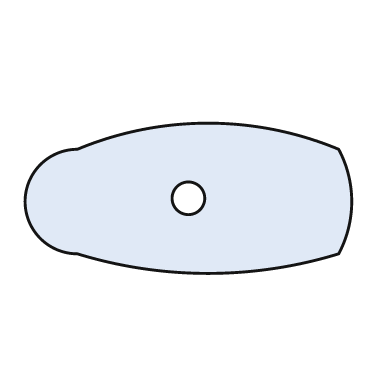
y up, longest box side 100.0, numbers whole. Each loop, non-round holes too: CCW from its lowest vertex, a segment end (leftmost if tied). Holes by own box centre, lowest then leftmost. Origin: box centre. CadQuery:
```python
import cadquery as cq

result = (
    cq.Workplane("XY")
    .moveTo(-34.0, -17.0)
    .threePointArc((6.0, -23.0), (46.0, -17.0))
    .threePointArc((50.0, -1.0), (46.0, 15.0))
    .threePointArc((6.0, 23.0), (-34.0, 15.0))
    .threePointArc((-50.0, -1.0), (-34.0, -17.0))
    .close()
    .moveTo(0.0, 0.0)
    .circle(5.0)
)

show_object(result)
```